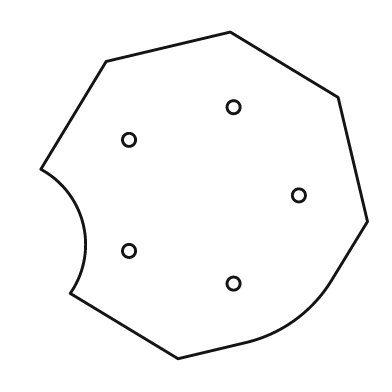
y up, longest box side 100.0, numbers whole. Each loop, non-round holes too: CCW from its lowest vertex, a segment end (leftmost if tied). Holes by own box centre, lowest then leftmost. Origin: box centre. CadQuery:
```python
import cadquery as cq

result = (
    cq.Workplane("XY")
    .moveTo(-8.0, -50.0)
    .lineTo(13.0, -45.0)
    .threePointArc((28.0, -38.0), (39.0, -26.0))
    .lineTo(50.0, -8.0)
    .lineTo(41.0, 30.0)
    .lineTo(8.0, 50.0)
    .lineTo(-30.0, 41.0)
    .lineTo(-50.0, 8.0)
    .threePointArc((-37.0, -9.0), (-41.0, -30.0))
    .close()
    .moveTo(9.0, -27.0)
    .circle(2.0)
    .moveTo(-23.0, -17.0)
    .circle(2.0)
    .moveTo(29.0, 0.0)
    .circle(2.0)
    .moveTo(-23.0, 17.0)
    .circle(2.0)
    .moveTo(9.0, 27.0)
    .circle(2.0)
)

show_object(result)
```